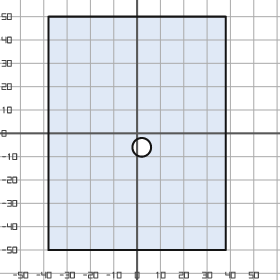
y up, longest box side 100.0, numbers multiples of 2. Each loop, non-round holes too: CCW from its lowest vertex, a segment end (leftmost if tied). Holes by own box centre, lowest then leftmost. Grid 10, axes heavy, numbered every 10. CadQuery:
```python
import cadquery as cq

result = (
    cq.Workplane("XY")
    .moveTo(-38.0, -50.0)
    .lineTo(38.0, -50.0)
    .lineTo(38.0, 50.0)
    .lineTo(-38.0, 50.0)
    .close()
    .moveTo(2.0, -6.0)
    .circle(4.0)
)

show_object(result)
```